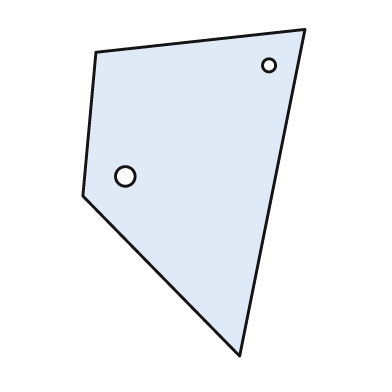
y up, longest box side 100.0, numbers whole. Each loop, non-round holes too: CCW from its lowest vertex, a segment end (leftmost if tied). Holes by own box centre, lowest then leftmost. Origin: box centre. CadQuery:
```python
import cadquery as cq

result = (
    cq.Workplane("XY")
    .moveTo(14.0, -50.0)
    .lineTo(34.0, 50.0)
    .lineTo(-30.0, 43.0)
    .lineTo(-34.0, -1.0)
    .close()
    .moveTo(-21.0, 5.0)
    .circle(3.0)
    .moveTo(23.0, 39.0)
    .circle(2.0)
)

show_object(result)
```